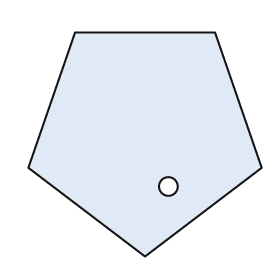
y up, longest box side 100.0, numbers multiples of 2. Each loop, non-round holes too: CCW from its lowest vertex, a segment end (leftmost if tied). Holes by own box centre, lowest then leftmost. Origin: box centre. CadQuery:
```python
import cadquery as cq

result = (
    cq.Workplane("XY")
    .moveTo(0.0, -48.0)
    .lineTo(50.0, -10.0)
    .lineTo(30.0, 48.0)
    .lineTo(-30.0, 48.0)
    .lineTo(-50.0, -10.0)
    .close()
    .moveTo(10.0, -18.0)
    .circle(4.0)
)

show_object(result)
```